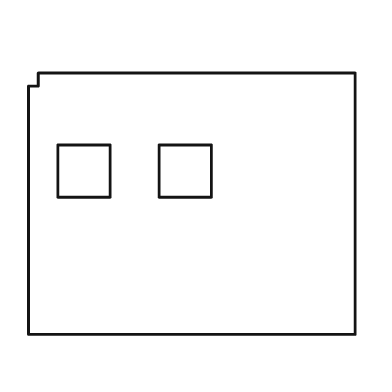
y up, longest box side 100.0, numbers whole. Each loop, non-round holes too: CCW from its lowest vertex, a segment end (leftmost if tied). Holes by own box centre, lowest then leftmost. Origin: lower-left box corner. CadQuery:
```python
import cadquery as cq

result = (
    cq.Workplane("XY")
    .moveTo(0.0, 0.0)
    .lineTo(100.0, 0.0)
    .lineTo(100.0, 80.0)
    .lineTo(3.0, 80.0)
    .lineTo(3.0, 76.0)
    .lineTo(0.0, 76.0)
    .close()
    .moveTo(9.0, 42.0)
    .lineTo(25.0, 42.0)
    .lineTo(25.0, 58.0)
    .lineTo(9.0, 58.0)
    .close()
    .moveTo(40.0, 42.0)
    .lineTo(56.0, 42.0)
    .lineTo(56.0, 58.0)
    .lineTo(40.0, 58.0)
    .close()
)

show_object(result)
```